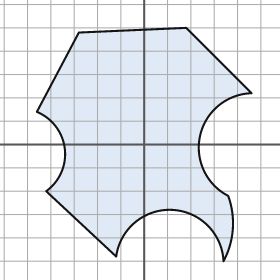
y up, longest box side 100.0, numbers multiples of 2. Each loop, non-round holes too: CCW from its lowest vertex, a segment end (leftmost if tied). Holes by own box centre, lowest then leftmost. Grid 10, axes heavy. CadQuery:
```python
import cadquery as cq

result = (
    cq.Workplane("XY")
    .moveTo(34.0, -50.0)
    .threePointArc((38.0, -36.0), (36.0, -22.0))
    .threePointArc((24.0, 4.0), (46.0, 22.0))
    .lineTo(18.0, 50.0)
    .lineTo(-28.0, 48.0)
    .lineTo(-46.0, 14.0)
    .threePointArc((-34.0, -2.0), (-42.0, -20.0))
    .lineTo(-12.0, -48.0)
    .threePointArc((12.0, -28.0), (34.0, -50.0))
    .close()
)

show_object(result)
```